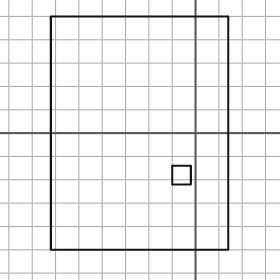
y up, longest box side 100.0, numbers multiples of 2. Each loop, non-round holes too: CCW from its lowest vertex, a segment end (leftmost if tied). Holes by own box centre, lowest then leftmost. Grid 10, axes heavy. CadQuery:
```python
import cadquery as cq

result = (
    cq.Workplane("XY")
    .moveTo(-62.0, -50.0)
    .lineTo(14.0, -50.0)
    .lineTo(14.0, 50.0)
    .lineTo(-62.0, 50.0)
    .close()
    .moveTo(-10.0, -22.0)
    .lineTo(-2.0, -22.0)
    .lineTo(-2.0, -14.0)
    .lineTo(-10.0, -14.0)
    .close()
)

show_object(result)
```